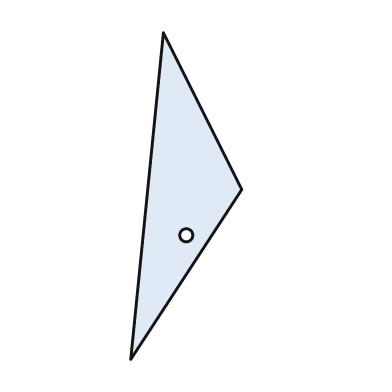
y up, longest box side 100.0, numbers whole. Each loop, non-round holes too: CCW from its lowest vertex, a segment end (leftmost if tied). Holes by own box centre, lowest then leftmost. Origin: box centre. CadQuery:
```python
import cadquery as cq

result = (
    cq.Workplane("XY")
    .moveTo(-17.0, -50.0)
    .lineTo(17.0, 2.0)
    .lineTo(-7.0, 50.0)
    .close()
    .moveTo(0.0, -12.0)
    .circle(2.0)
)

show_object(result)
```